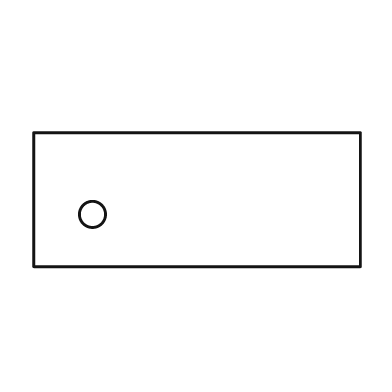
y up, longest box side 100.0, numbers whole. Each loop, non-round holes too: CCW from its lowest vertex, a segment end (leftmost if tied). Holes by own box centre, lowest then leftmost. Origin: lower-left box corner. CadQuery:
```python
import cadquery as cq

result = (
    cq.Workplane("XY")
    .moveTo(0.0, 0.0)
    .lineTo(100.0, 0.0)
    .lineTo(100.0, 41.0)
    .lineTo(0.0, 41.0)
    .close()
    .moveTo(18.0, 16.0)
    .circle(4.0)
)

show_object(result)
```